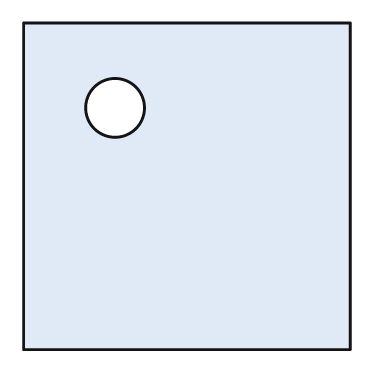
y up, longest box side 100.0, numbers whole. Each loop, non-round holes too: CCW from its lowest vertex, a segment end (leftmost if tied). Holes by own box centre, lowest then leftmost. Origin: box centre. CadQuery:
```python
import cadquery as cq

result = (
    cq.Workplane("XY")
    .moveTo(-50.0, -50.0)
    .lineTo(50.0, -50.0)
    .lineTo(50.0, 50.0)
    .lineTo(-50.0, 50.0)
    .close()
    .moveTo(-22.0, 24.0)
    .circle(9.0)
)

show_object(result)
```